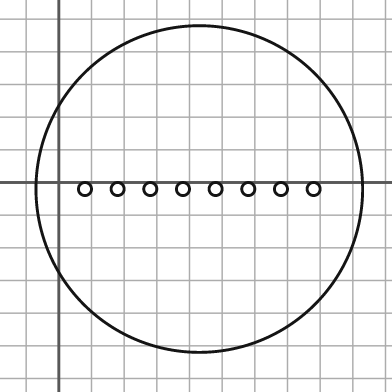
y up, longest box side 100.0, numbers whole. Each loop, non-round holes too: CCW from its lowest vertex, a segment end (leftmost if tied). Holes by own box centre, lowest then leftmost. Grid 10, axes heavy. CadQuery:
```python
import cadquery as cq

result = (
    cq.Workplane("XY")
    .moveTo(43.0, -2.0)
    .circle(50.0)
    .moveTo(8.0, -2.0)
    .circle(2.0)
    .moveTo(18.0, -2.0)
    .circle(2.0)
    .moveTo(28.0, -2.0)
    .circle(2.0)
    .moveTo(38.0, -2.0)
    .circle(2.0)
    .moveTo(48.0, -2.0)
    .circle(2.0)
    .moveTo(58.0, -2.0)
    .circle(2.0)
    .moveTo(68.0, -2.0)
    .circle(2.0)
    .moveTo(78.0, -2.0)
    .circle(2.0)
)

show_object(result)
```